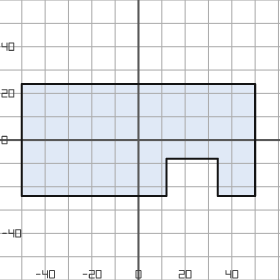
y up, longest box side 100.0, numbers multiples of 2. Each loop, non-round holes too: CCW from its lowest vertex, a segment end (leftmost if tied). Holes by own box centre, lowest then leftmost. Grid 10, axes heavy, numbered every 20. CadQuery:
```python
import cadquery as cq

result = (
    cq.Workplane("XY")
    .moveTo(-50.0, -24.0)
    .lineTo(12.0, -24.0)
    .lineTo(12.0, -8.0)
    .lineTo(34.0, -8.0)
    .lineTo(34.0, -24.0)
    .lineTo(50.0, -24.0)
    .lineTo(50.0, 24.0)
    .lineTo(-50.0, 24.0)
    .close()
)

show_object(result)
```